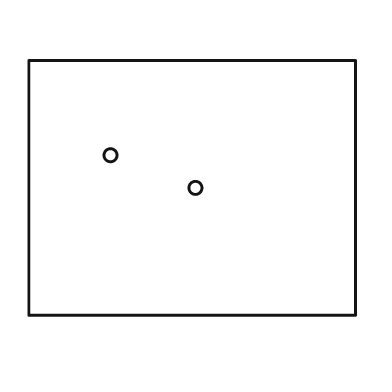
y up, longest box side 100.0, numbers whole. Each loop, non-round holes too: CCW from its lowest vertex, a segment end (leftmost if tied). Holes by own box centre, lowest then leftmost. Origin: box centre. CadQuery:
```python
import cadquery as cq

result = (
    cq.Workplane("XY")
    .moveTo(-50.0, -39.0)
    .lineTo(50.0, -39.0)
    .lineTo(50.0, 39.0)
    .lineTo(-50.0, 39.0)
    .close()
    .moveTo(1.0, 0.0)
    .circle(2.0)
    .moveTo(-25.0, 10.0)
    .circle(2.0)
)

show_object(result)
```